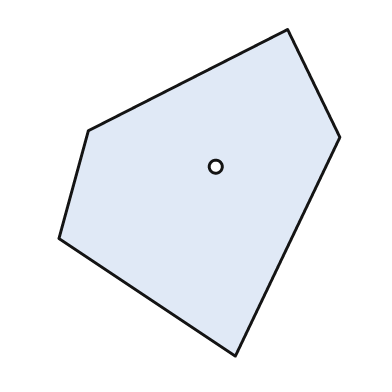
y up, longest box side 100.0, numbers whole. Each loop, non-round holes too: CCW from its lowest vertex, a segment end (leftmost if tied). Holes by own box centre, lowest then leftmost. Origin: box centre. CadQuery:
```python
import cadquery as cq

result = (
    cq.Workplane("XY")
    .moveTo(11.0, -50.0)
    .lineTo(43.0, 17.0)
    .lineTo(27.0, 50.0)
    .lineTo(-34.0, 19.0)
    .lineTo(-43.0, -14.0)
    .close()
    .moveTo(5.0, 8.0)
    .circle(2.0)
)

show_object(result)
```